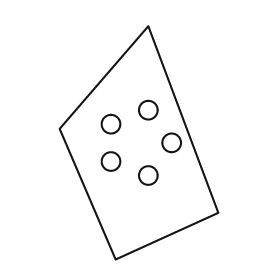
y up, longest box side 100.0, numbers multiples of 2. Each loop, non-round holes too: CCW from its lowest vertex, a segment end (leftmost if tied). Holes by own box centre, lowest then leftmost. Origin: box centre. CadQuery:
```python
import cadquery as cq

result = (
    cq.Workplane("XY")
    .moveTo(-10.0, -50.0)
    .lineTo(34.0, -30.0)
    .lineTo(4.0, 50.0)
    .lineTo(-34.0, 6.0)
    .close()
    .moveTo(4.0, -14.0)
    .circle(4.0)
    .moveTo(-12.0, -8.0)
    .circle(4.0)
    .moveTo(14.0, 0.0)
    .circle(4.0)
    .moveTo(-12.0, 8.0)
    .circle(4.0)
    .moveTo(4.0, 14.0)
    .circle(4.0)
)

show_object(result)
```